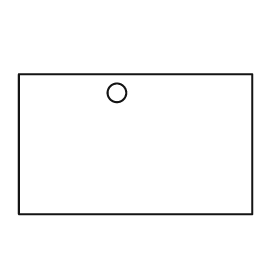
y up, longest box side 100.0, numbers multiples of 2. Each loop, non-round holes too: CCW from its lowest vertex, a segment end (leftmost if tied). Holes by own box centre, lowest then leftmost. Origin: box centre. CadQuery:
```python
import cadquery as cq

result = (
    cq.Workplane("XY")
    .moveTo(-50.0, -30.0)
    .lineTo(50.0, -30.0)
    .lineTo(50.0, 30.0)
    .lineTo(-50.0, 30.0)
    .close()
    .moveTo(-8.0, 22.0)
    .circle(4.0)
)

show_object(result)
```